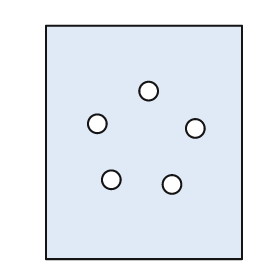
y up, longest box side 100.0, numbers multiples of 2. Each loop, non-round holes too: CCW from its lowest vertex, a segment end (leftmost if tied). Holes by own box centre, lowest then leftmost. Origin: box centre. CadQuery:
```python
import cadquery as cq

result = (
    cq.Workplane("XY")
    .moveTo(-42.0, -50.0)
    .lineTo(42.0, -50.0)
    .lineTo(42.0, 50.0)
    .lineTo(-42.0, 50.0)
    .close()
    .moveTo(12.0, -18.0)
    .circle(4.0)
    .moveTo(-14.0, -16.0)
    .circle(4.0)
    .moveTo(22.0, 6.0)
    .circle(4.0)
    .moveTo(-20.0, 8.0)
    .circle(4.0)
    .moveTo(2.0, 22.0)
    .circle(4.0)
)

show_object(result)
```